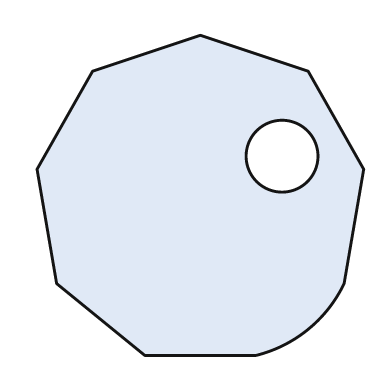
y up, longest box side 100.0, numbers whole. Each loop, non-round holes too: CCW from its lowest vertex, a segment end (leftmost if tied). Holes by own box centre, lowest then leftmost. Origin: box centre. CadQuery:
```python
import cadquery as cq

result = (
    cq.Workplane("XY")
    .moveTo(-17.0, -49.0)
    .lineTo(17.0, -49.0)
    .threePointArc((33.0, -41.0), (44.0, -27.0))
    .lineTo(50.0, 8.0)
    .lineTo(33.0, 38.0)
    .lineTo(0.0, 49.0)
    .lineTo(-33.0, 38.0)
    .lineTo(-50.0, 8.0)
    .lineTo(-44.0, -27.0)
    .close()
    .moveTo(25.0, 12.0)
    .circle(11.0)
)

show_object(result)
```